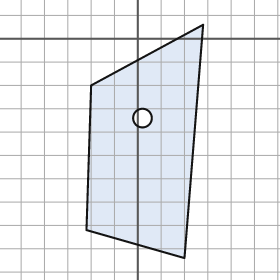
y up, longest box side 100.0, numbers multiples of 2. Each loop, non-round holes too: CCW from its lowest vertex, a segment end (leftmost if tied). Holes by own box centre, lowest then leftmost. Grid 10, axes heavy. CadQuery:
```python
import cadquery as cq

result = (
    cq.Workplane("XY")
    .moveTo(20.0, -94.0)
    .lineTo(28.0, 6.0)
    .lineTo(-20.0, -20.0)
    .lineTo(-22.0, -82.0)
    .close()
    .moveTo(2.0, -34.0)
    .circle(4.0)
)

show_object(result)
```